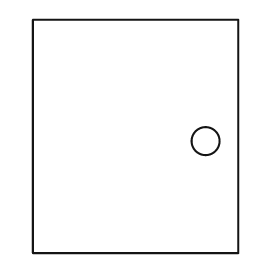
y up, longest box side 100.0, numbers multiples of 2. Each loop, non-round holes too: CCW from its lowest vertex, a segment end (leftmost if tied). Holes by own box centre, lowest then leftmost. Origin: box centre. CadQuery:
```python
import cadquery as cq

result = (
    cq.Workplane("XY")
    .moveTo(-44.0, -50.0)
    .lineTo(44.0, -50.0)
    .lineTo(44.0, 50.0)
    .lineTo(-44.0, 50.0)
    .close()
    .moveTo(30.0, -2.0)
    .circle(6.0)
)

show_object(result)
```